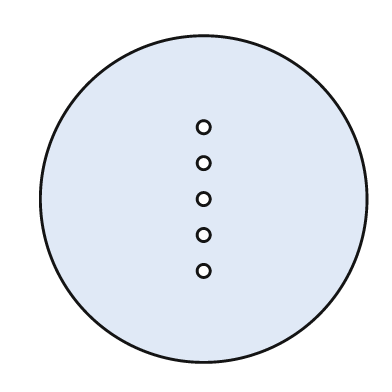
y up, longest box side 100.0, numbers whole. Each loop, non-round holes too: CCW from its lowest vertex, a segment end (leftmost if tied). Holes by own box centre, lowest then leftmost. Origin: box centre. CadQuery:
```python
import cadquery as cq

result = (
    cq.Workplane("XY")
    .moveTo(0.0, 0.0)
    .circle(50.0)
    .moveTo(0.0, -22.0)
    .circle(2.0)
    .moveTo(0.0, -11.0)
    .circle(2.0)
    .moveTo(0.0, 0.0)
    .circle(2.0)
    .moveTo(0.0, 11.0)
    .circle(2.0)
    .moveTo(0.0, 22.0)
    .circle(2.0)
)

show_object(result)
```